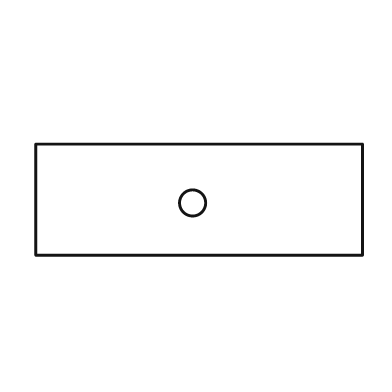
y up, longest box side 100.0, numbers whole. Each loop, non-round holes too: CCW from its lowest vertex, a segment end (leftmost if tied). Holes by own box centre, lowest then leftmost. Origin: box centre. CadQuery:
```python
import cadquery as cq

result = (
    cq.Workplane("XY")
    .moveTo(-50.0, -17.0)
    .lineTo(50.0, -17.0)
    .lineTo(50.0, 17.0)
    .lineTo(-50.0, 17.0)
    .close()
    .moveTo(-2.0, -1.0)
    .circle(4.0)
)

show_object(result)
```